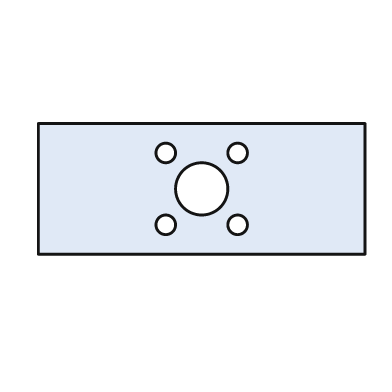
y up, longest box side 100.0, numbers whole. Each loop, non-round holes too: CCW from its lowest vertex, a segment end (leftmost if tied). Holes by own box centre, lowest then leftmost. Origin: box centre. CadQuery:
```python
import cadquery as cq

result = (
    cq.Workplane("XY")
    .moveTo(-50.0, -20.0)
    .lineTo(50.0, -20.0)
    .lineTo(50.0, 20.0)
    .lineTo(-50.0, 20.0)
    .close()
    .moveTo(-11.0, -11.0)
    .circle(3.0)
    .moveTo(11.0, -11.0)
    .circle(3.0)
    .moveTo(0.0, 0.0)
    .circle(8.0)
    .moveTo(-11.0, 11.0)
    .circle(3.0)
    .moveTo(11.0, 11.0)
    .circle(3.0)
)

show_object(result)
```